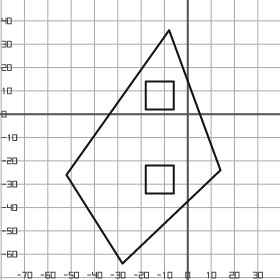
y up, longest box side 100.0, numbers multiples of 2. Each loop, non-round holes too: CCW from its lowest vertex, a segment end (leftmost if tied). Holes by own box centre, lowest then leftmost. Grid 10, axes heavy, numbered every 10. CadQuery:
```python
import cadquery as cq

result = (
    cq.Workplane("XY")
    .moveTo(-28.0, -64.0)
    .lineTo(14.0, -24.0)
    .lineTo(-8.0, 36.0)
    .lineTo(-52.0, -26.0)
    .close()
    .moveTo(-18.0, -34.0)
    .lineTo(-6.0, -34.0)
    .lineTo(-6.0, -22.0)
    .lineTo(-18.0, -22.0)
    .close()
    .moveTo(-18.0, 2.0)
    .lineTo(-6.0, 2.0)
    .lineTo(-6.0, 14.0)
    .lineTo(-18.0, 14.0)
    .close()
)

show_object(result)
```